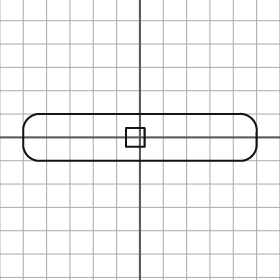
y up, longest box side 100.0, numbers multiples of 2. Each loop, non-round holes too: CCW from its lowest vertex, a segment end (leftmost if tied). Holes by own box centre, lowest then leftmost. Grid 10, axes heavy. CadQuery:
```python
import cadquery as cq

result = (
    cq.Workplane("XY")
    .moveTo(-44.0, -10.0)
    .lineTo(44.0, -10.0)
    .threePointArc((48.0, -8.0), (50.0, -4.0))
    .lineTo(50.0, 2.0)
    .threePointArc((48.0, 8.0), (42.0, 10.0))
    .lineTo(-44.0, 10.0)
    .threePointArc((-48.0, 8.0), (-50.0, 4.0))
    .lineTo(-50.0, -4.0)
    .threePointArc((-48.0, -8.0), (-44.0, -10.0))
    .close()
    .moveTo(-6.0, -4.0)
    .lineTo(2.0, -4.0)
    .lineTo(2.0, 4.0)
    .lineTo(-6.0, 4.0)
    .close()
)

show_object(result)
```